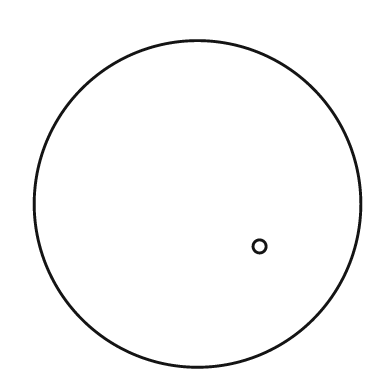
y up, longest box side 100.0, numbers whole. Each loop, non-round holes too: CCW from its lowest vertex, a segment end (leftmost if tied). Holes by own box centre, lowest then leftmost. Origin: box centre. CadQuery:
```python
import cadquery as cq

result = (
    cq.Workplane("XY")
    .moveTo(0.0, 0.0)
    .circle(50.0)
    .moveTo(19.0, -13.0)
    .circle(2.0)
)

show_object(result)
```